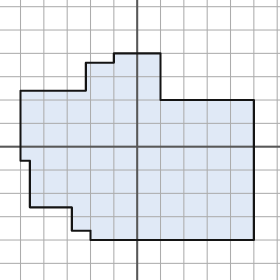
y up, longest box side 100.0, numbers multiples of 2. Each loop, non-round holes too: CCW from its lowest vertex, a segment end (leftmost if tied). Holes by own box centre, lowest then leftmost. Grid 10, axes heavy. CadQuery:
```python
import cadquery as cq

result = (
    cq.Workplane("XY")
    .moveTo(-20.0, -40.0)
    .lineTo(50.0, -40.0)
    .lineTo(50.0, 20.0)
    .lineTo(10.0, 20.0)
    .lineTo(10.0, 40.0)
    .lineTo(-10.0, 40.0)
    .lineTo(-10.0, 36.0)
    .lineTo(-22.0, 36.0)
    .lineTo(-22.0, 24.0)
    .lineTo(-50.0, 24.0)
    .lineTo(-50.0, -6.0)
    .lineTo(-46.0, -6.0)
    .lineTo(-46.0, -26.0)
    .lineTo(-28.0, -26.0)
    .lineTo(-28.0, -36.0)
    .lineTo(-20.0, -36.0)
    .close()
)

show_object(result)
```